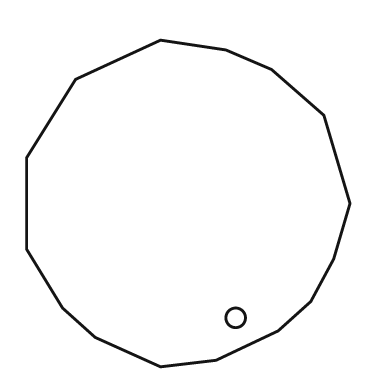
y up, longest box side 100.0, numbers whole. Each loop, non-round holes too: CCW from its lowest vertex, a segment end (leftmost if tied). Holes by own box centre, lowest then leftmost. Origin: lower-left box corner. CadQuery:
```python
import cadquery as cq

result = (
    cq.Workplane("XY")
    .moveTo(41.0, 0.0)
    .lineTo(58.0, 2.0)
    .lineTo(77.0, 11.0)
    .lineTo(87.0, 20.0)
    .lineTo(94.0, 33.0)
    .lineTo(99.0, 50.0)
    .lineTo(91.0, 77.0)
    .lineTo(75.0, 91.0)
    .lineTo(61.0, 97.0)
    .lineTo(41.0, 100.0)
    .lineTo(15.0, 88.0)
    .lineTo(0.0, 64.0)
    .lineTo(0.0, 36.0)
    .lineTo(11.0, 18.0)
    .lineTo(21.0, 9.0)
    .close()
    .moveTo(64.0, 15.0)
    .circle(3.0)
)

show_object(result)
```